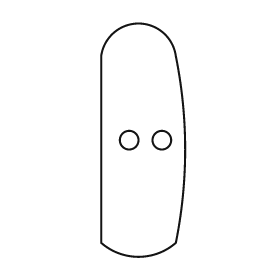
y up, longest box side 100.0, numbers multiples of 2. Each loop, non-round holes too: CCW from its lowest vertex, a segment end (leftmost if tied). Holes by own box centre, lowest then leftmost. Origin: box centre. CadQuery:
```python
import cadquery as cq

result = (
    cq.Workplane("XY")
    .moveTo(-18.0, -44.0)
    .threePointArc((-2.0, -50.0), (14.0, -44.0))
    .threePointArc((18.0, -4.0), (14.0, 36.0))
    .threePointArc((-2.0, 50.0), (-18.0, 36.0))
    .close()
    .moveTo(-6.0, 0.0)
    .circle(4.0)
    .moveTo(8.0, 0.0)
    .circle(4.0)
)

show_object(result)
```